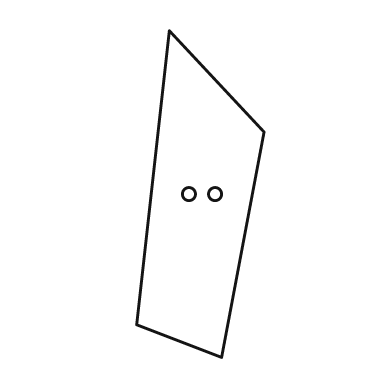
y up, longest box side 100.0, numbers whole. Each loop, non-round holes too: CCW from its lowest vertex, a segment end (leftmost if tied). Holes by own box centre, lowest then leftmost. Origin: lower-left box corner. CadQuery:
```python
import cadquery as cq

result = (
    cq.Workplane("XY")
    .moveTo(26.0, 0.0)
    .lineTo(39.0, 69.0)
    .lineTo(10.0, 100.0)
    .lineTo(0.0, 10.0)
    .close()
    .moveTo(16.0, 50.0)
    .circle(2.0)
    .moveTo(24.0, 50.0)
    .circle(2.0)
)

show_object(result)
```